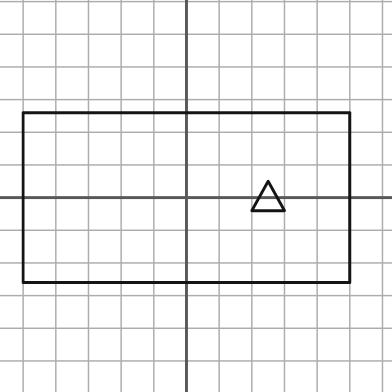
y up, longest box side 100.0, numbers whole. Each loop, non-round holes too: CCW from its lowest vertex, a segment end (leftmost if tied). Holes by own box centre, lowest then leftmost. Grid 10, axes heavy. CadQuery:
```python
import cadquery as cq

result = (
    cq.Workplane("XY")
    .moveTo(-50.0, -26.0)
    .lineTo(50.0, -26.0)
    .lineTo(50.0, 26.0)
    .lineTo(-50.0, 26.0)
    .close()
    .moveTo(20.0, -4.0)
    .lineTo(30.0, -4.0)
    .lineTo(25.0, 5.0)
    .close()
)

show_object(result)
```